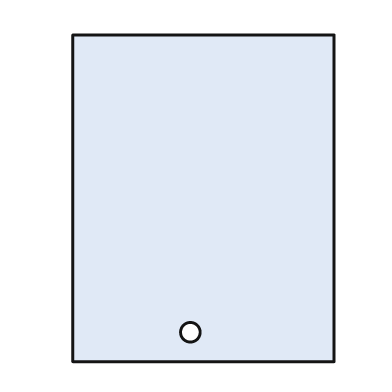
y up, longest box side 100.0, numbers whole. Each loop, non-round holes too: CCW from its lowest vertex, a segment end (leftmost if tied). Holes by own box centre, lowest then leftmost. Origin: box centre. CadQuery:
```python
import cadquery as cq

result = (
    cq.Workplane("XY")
    .moveTo(-40.0, -50.0)
    .lineTo(40.0, -50.0)
    .lineTo(40.0, 50.0)
    .lineTo(-40.0, 50.0)
    .close()
    .moveTo(-4.0, -41.0)
    .circle(3.0)
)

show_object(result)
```